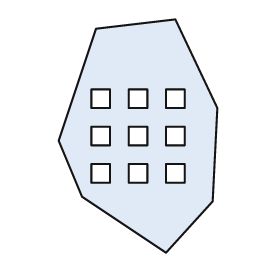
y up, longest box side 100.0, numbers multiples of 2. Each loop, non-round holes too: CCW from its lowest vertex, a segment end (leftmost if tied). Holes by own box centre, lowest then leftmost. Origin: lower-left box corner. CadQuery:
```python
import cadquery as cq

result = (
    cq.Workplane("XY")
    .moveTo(46.0, 0.0)
    .lineTo(66.0, 22.0)
    .lineTo(68.0, 62.0)
    .lineTo(50.0, 100.0)
    .lineTo(16.0, 96.0)
    .lineTo(0.0, 48.0)
    .lineTo(10.0, 24.0)
    .close()
    .moveTo(14.0, 30.0)
    .lineTo(22.0, 30.0)
    .lineTo(22.0, 38.0)
    .lineTo(14.0, 38.0)
    .close()
    .moveTo(30.0, 30.0)
    .lineTo(38.0, 30.0)
    .lineTo(38.0, 38.0)
    .lineTo(30.0, 38.0)
    .close()
    .moveTo(46.0, 30.0)
    .lineTo(54.0, 30.0)
    .lineTo(54.0, 38.0)
    .lineTo(46.0, 38.0)
    .close()
    .moveTo(14.0, 46.0)
    .lineTo(22.0, 46.0)
    .lineTo(22.0, 54.0)
    .lineTo(14.0, 54.0)
    .close()
    .moveTo(30.0, 46.0)
    .lineTo(38.0, 46.0)
    .lineTo(38.0, 54.0)
    .lineTo(30.0, 54.0)
    .close()
    .moveTo(46.0, 46.0)
    .lineTo(54.0, 46.0)
    .lineTo(54.0, 54.0)
    .lineTo(46.0, 54.0)
    .close()
    .moveTo(14.0, 62.0)
    .lineTo(22.0, 62.0)
    .lineTo(22.0, 70.0)
    .lineTo(14.0, 70.0)
    .close()
    .moveTo(30.0, 62.0)
    .lineTo(38.0, 62.0)
    .lineTo(38.0, 70.0)
    .lineTo(30.0, 70.0)
    .close()
    .moveTo(46.0, 62.0)
    .lineTo(54.0, 62.0)
    .lineTo(54.0, 70.0)
    .lineTo(46.0, 70.0)
    .close()
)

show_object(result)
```